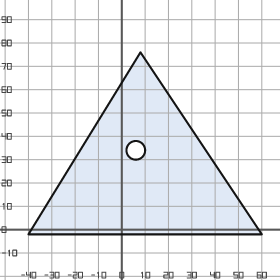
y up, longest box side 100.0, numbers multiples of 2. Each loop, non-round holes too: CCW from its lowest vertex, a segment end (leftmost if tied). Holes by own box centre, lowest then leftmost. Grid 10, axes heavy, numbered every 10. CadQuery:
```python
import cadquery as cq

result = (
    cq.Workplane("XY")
    .moveTo(-40.0, -2.0)
    .lineTo(60.0, -2.0)
    .lineTo(8.0, 76.0)
    .close()
    .moveTo(6.0, 34.0)
    .circle(4.0)
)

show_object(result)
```